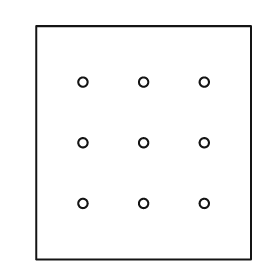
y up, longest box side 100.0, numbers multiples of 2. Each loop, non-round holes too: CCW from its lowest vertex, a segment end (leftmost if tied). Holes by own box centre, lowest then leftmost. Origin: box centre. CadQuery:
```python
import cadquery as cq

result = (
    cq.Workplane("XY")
    .moveTo(-46.0, -50.0)
    .lineTo(46.0, -50.0)
    .lineTo(46.0, 50.0)
    .lineTo(-46.0, 50.0)
    .close()
    .moveTo(-26.0, -26.0)
    .circle(2.0)
    .moveTo(0.0, -26.0)
    .circle(2.0)
    .moveTo(26.0, -26.0)
    .circle(2.0)
    .moveTo(-26.0, 0.0)
    .circle(2.0)
    .moveTo(0.0, 0.0)
    .circle(2.0)
    .moveTo(26.0, 0.0)
    .circle(2.0)
    .moveTo(-26.0, 26.0)
    .circle(2.0)
    .moveTo(0.0, 26.0)
    .circle(2.0)
    .moveTo(26.0, 26.0)
    .circle(2.0)
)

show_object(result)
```